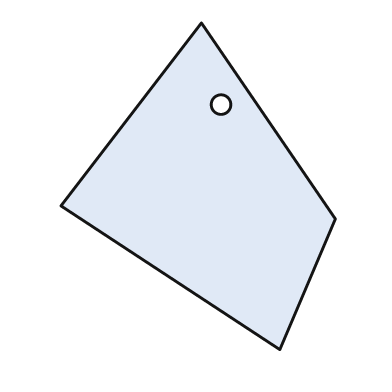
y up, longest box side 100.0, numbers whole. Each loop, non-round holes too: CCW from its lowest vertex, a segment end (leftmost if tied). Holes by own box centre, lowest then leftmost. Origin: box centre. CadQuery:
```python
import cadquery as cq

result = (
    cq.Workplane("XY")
    .moveTo(25.0, -50.0)
    .lineTo(42.0, -10.0)
    .lineTo(1.0, 50.0)
    .lineTo(-42.0, -6.0)
    .close()
    .moveTo(7.0, 25.0)
    .circle(3.0)
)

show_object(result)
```